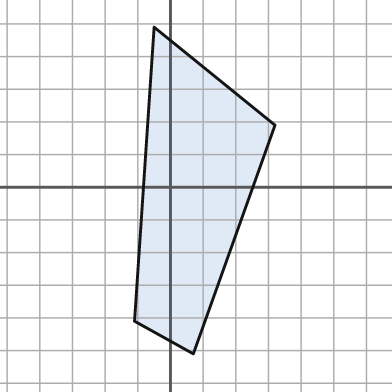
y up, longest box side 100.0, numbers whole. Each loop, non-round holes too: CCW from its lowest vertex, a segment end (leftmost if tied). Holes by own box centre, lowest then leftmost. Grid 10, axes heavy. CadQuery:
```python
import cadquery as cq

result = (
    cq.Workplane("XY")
    .moveTo(7.0, -51.0)
    .lineTo(32.0, 19.0)
    .lineTo(-5.0, 49.0)
    .lineTo(-11.0, -41.0)
    .close()
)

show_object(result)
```